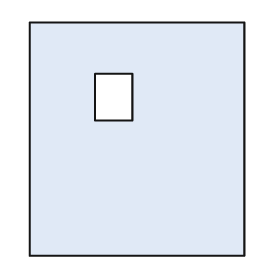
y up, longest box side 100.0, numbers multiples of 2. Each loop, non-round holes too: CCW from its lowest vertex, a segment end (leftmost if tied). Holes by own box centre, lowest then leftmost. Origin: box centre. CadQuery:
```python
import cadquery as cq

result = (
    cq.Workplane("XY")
    .moveTo(-46.0, -50.0)
    .lineTo(46.0, -50.0)
    .lineTo(46.0, 50.0)
    .lineTo(-46.0, 50.0)
    .close()
    .moveTo(-18.0, 8.0)
    .lineTo(-2.0, 8.0)
    .lineTo(-2.0, 28.0)
    .lineTo(-18.0, 28.0)
    .close()
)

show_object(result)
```